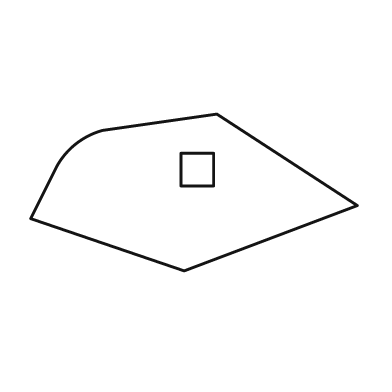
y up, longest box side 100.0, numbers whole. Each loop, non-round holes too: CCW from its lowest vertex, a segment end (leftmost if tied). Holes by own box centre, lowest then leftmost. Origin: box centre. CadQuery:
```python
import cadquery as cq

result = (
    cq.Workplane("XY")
    .moveTo(-3.0, -24.0)
    .lineTo(50.0, -4.0)
    .lineTo(7.0, 24.0)
    .lineTo(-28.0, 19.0)
    .threePointArc((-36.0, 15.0), (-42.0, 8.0))
    .lineTo(-50.0, -8.0)
    .close()
    .moveTo(-4.0, 2.0)
    .lineTo(6.0, 2.0)
    .lineTo(6.0, 12.0)
    .lineTo(-4.0, 12.0)
    .close()
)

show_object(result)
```